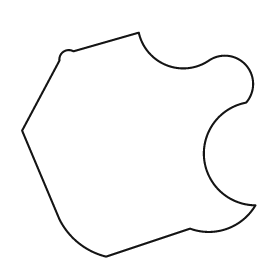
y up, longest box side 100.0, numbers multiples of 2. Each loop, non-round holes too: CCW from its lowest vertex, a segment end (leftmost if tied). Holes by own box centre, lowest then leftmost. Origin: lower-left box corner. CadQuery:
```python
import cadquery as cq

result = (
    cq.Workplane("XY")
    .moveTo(36.0, 0.0)
    .lineTo(72.0, 12.0)
    .threePointArc((88.0, 12.0), (100.0, 22.0))
    .threePointArc((78.0, 42.0), (96.0, 66.0))
    .threePointArc((96.0, 82.0), (80.0, 84.0))
    .threePointArc((62.0, 82.0), (50.0, 96.0))
    .lineTo(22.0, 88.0)
    .threePointArc((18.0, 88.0), (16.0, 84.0))
    .lineTo(0.0, 54.0)
    .lineTo(16.0, 16.0)
    .threePointArc((24.0, 6.0), (36.0, 0.0))
    .close()
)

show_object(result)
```